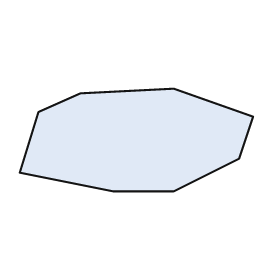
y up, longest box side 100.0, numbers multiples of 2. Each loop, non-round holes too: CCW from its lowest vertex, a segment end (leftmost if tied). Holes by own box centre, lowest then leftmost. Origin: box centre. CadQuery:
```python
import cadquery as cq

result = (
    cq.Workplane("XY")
    .moveTo(-10.0, -22.0)
    .lineTo(16.0, -22.0)
    .lineTo(44.0, -8.0)
    .lineTo(50.0, 10.0)
    .lineTo(16.0, 22.0)
    .lineTo(-24.0, 20.0)
    .lineTo(-42.0, 12.0)
    .lineTo(-50.0, -14.0)
    .close()
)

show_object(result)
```